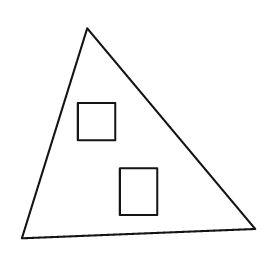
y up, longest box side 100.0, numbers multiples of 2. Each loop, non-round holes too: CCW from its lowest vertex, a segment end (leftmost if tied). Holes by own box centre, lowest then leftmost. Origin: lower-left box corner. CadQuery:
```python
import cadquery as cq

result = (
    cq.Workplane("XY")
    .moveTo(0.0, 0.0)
    .lineTo(100.0, 4.0)
    .lineTo(28.0, 90.0)
    .close()
    .moveTo(42.0, 10.0)
    .lineTo(58.0, 10.0)
    .lineTo(58.0, 30.0)
    .lineTo(42.0, 30.0)
    .close()
    .moveTo(24.0, 42.0)
    .lineTo(40.0, 42.0)
    .lineTo(40.0, 58.0)
    .lineTo(24.0, 58.0)
    .close()
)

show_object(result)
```